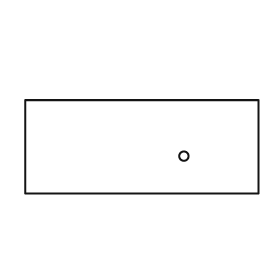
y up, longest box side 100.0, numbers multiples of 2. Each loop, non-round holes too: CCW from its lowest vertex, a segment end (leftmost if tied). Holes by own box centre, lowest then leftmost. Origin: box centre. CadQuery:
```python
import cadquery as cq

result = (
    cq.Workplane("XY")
    .moveTo(-50.0, -20.0)
    .lineTo(50.0, -20.0)
    .lineTo(50.0, 20.0)
    .lineTo(-50.0, 20.0)
    .close()
    .moveTo(18.0, -4.0)
    .circle(2.0)
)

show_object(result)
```